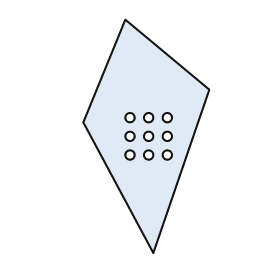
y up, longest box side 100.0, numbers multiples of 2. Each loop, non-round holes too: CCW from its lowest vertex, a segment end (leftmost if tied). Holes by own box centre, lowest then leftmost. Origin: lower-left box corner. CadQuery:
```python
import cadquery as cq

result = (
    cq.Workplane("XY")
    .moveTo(30.0, 0.0)
    .lineTo(54.0, 70.0)
    .lineTo(18.0, 100.0)
    .lineTo(0.0, 56.0)
    .close()
    .moveTo(20.0, 42.0)
    .circle(2.0)
    .moveTo(28.0, 42.0)
    .circle(2.0)
    .moveTo(36.0, 42.0)
    .circle(2.0)
    .moveTo(20.0, 50.0)
    .circle(2.0)
    .moveTo(28.0, 50.0)
    .circle(2.0)
    .moveTo(36.0, 50.0)
    .circle(2.0)
    .moveTo(20.0, 58.0)
    .circle(2.0)
    .moveTo(28.0, 58.0)
    .circle(2.0)
    .moveTo(36.0, 58.0)
    .circle(2.0)
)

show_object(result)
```